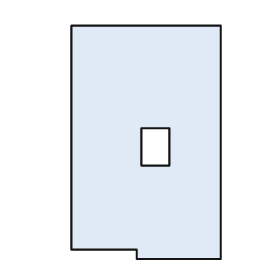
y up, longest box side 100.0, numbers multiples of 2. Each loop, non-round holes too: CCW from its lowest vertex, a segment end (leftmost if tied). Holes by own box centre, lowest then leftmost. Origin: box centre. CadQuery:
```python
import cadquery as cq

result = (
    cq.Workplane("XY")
    .moveTo(-4.0, -50.0)
    .lineTo(32.0, -50.0)
    .lineTo(32.0, 50.0)
    .lineTo(-32.0, 50.0)
    .lineTo(-32.0, -46.0)
    .lineTo(-4.0, -46.0)
    .close()
    .moveTo(-2.0, -10.0)
    .lineTo(10.0, -10.0)
    .lineTo(10.0, 6.0)
    .lineTo(-2.0, 6.0)
    .close()
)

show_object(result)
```